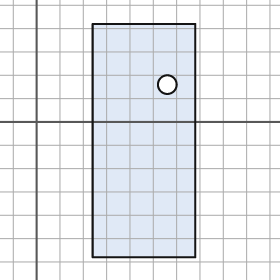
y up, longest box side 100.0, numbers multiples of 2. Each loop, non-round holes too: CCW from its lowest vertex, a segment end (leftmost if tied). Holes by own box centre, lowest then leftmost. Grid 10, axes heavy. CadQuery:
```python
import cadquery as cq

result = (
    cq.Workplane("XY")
    .moveTo(24.0, -58.0)
    .lineTo(68.0, -58.0)
    .lineTo(68.0, 42.0)
    .lineTo(24.0, 42.0)
    .close()
    .moveTo(56.0, 16.0)
    .circle(4.0)
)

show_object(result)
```